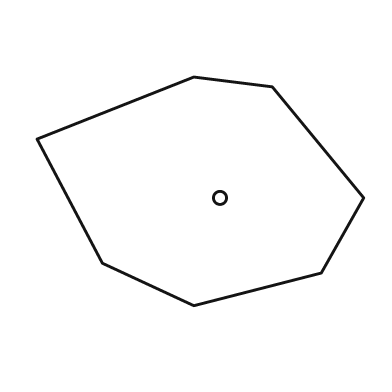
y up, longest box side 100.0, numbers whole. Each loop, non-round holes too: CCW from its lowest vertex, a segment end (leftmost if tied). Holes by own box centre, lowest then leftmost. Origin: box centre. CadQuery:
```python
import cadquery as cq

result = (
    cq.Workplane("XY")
    .moveTo(-2.0, -35.0)
    .lineTo(37.0, -25.0)
    .lineTo(50.0, -2.0)
    .lineTo(22.0, 32.0)
    .lineTo(-2.0, 35.0)
    .lineTo(-50.0, 16.0)
    .lineTo(-30.0, -22.0)
    .close()
    .moveTo(6.0, -2.0)
    .circle(2.0)
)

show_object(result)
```